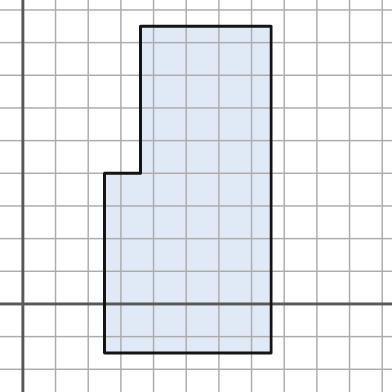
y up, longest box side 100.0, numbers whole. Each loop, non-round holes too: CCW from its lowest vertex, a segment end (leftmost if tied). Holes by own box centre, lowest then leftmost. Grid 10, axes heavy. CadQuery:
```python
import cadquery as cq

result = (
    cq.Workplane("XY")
    .moveTo(25.0, -15.0)
    .lineTo(76.0, -15.0)
    .lineTo(76.0, 85.0)
    .lineTo(36.0, 85.0)
    .lineTo(36.0, 40.0)
    .lineTo(25.0, 40.0)
    .close()
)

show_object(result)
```